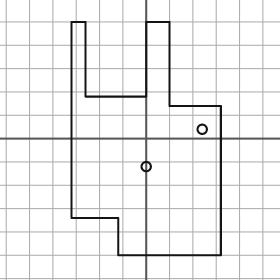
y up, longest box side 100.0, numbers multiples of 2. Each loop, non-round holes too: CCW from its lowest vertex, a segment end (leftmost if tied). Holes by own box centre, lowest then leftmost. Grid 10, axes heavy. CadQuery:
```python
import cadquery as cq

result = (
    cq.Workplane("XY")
    .moveTo(-12.0, -50.0)
    .lineTo(32.0, -50.0)
    .lineTo(32.0, 14.0)
    .lineTo(10.0, 14.0)
    .lineTo(10.0, 50.0)
    .lineTo(0.0, 50.0)
    .lineTo(0.0, 18.0)
    .lineTo(-26.0, 18.0)
    .lineTo(-26.0, 50.0)
    .lineTo(-32.0, 50.0)
    .lineTo(-32.0, -34.0)
    .lineTo(-12.0, -34.0)
    .close()
    .moveTo(0.0, -12.0)
    .circle(2.0)
    .moveTo(24.0, 4.0)
    .circle(2.0)
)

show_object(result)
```